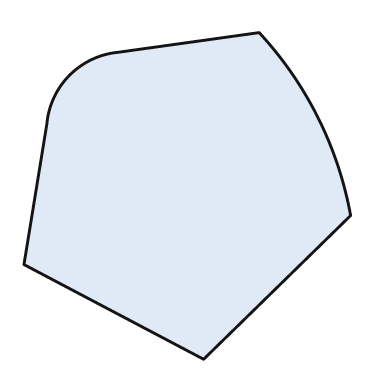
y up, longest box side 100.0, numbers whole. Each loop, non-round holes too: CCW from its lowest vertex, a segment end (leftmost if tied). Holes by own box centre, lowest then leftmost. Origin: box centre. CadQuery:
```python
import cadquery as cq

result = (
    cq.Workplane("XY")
    .moveTo(5.0, -50.0)
    .lineTo(50.0, -6.0)
    .threePointArc((40.0, 24.0), (22.0, 50.0))
    .lineTo(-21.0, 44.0)
    .threePointArc((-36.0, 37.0), (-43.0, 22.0))
    .lineTo(-50.0, -21.0)
    .close()
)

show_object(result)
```